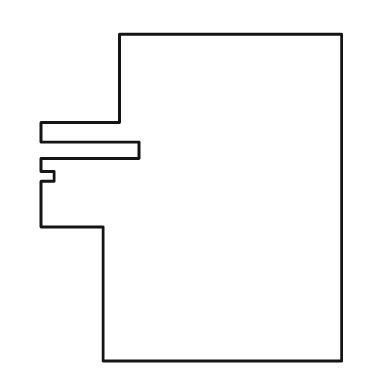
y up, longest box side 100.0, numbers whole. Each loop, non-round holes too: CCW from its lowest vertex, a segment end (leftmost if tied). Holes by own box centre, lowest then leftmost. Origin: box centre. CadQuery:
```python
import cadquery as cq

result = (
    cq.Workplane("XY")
    .moveTo(-27.0, -50.0)
    .lineTo(46.0, -50.0)
    .lineTo(46.0, 50.0)
    .lineTo(-22.0, 50.0)
    .lineTo(-22.0, 23.0)
    .lineTo(-46.0, 23.0)
    .lineTo(-46.0, 17.0)
    .lineTo(-16.0, 17.0)
    .lineTo(-16.0, 12.0)
    .lineTo(-46.0, 12.0)
    .lineTo(-46.0, 8.0)
    .lineTo(-42.0, 8.0)
    .lineTo(-42.0, 5.0)
    .lineTo(-46.0, 5.0)
    .lineTo(-46.0, -9.0)
    .lineTo(-27.0, -9.0)
    .close()
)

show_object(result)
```